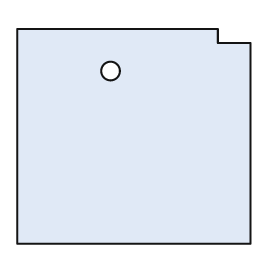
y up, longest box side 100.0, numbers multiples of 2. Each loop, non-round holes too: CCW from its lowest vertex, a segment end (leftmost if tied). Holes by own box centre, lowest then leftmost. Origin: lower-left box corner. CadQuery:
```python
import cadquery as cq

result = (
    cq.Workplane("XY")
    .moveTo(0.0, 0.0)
    .lineTo(100.0, 0.0)
    .lineTo(100.0, 86.0)
    .lineTo(86.0, 86.0)
    .lineTo(86.0, 92.0)
    .lineTo(0.0, 92.0)
    .close()
    .moveTo(40.0, 74.0)
    .circle(4.0)
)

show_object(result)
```